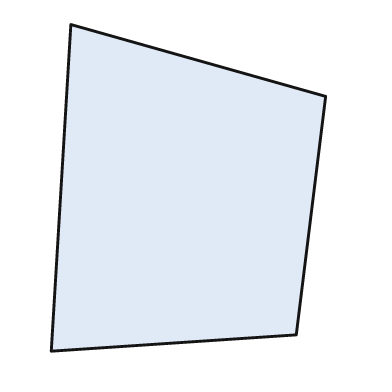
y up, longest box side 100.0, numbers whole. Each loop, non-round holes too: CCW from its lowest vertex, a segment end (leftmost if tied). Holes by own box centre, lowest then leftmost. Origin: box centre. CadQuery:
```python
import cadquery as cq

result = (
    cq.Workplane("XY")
    .moveTo(-42.0, -50.0)
    .lineTo(33.0, -45.0)
    .lineTo(42.0, 28.0)
    .lineTo(-36.0, 50.0)
    .close()
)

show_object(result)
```